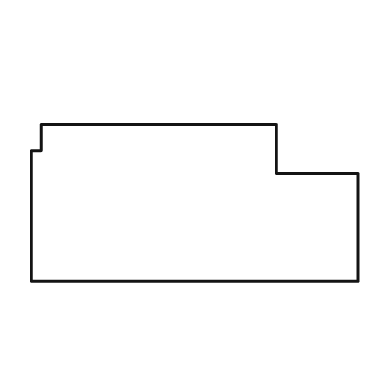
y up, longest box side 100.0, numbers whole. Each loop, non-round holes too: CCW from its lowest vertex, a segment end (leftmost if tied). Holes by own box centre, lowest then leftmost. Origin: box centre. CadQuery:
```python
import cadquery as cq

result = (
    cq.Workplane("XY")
    .moveTo(-50.0, -24.0)
    .lineTo(50.0, -24.0)
    .lineTo(50.0, 9.0)
    .lineTo(25.0, 9.0)
    .lineTo(25.0, 24.0)
    .lineTo(-47.0, 24.0)
    .lineTo(-47.0, 16.0)
    .lineTo(-50.0, 16.0)
    .close()
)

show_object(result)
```